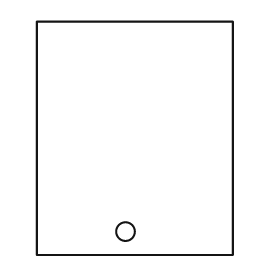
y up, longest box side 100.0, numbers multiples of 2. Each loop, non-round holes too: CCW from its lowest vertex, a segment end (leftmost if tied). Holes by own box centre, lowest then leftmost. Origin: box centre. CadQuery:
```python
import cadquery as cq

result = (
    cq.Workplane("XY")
    .moveTo(-42.0, -50.0)
    .lineTo(42.0, -50.0)
    .lineTo(42.0, 50.0)
    .lineTo(-42.0, 50.0)
    .close()
    .moveTo(-4.0, -40.0)
    .circle(4.0)
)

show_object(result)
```